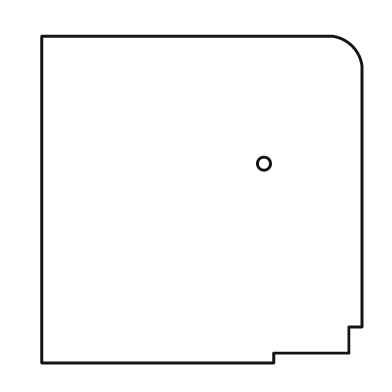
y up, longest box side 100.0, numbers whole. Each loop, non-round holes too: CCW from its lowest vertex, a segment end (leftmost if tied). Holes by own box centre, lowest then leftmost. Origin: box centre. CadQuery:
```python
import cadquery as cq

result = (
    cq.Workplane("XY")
    .moveTo(-49.0, -50.0)
    .lineTo(22.0, -50.0)
    .lineTo(22.0, -47.0)
    .lineTo(45.0, -47.0)
    .lineTo(45.0, -39.0)
    .lineTo(49.0, -39.0)
    .lineTo(49.0, 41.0)
    .threePointArc((46.0, 47.0), (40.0, 50.0))
    .lineTo(-49.0, 50.0)
    .close()
    .moveTo(19.0, 11.0)
    .circle(2.0)
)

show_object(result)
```